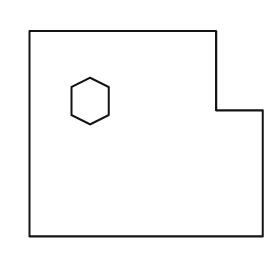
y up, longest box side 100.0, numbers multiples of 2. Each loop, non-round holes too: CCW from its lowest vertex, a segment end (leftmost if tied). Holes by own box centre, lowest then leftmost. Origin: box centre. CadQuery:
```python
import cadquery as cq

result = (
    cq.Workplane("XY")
    .moveTo(-50.0, -44.0)
    .lineTo(50.0, -44.0)
    .lineTo(50.0, 10.0)
    .lineTo(30.0, 10.0)
    .lineTo(30.0, 44.0)
    .lineTo(-50.0, 44.0)
    .close()
    .moveTo(-24.0, 4.0)
    .lineTo(-16.0, 8.0)
    .lineTo(-16.0, 20.0)
    .lineTo(-24.0, 24.0)
    .lineTo(-32.0, 20.0)
    .lineTo(-32.0, 8.0)
    .close()
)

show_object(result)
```